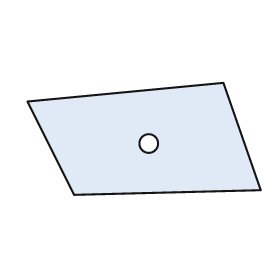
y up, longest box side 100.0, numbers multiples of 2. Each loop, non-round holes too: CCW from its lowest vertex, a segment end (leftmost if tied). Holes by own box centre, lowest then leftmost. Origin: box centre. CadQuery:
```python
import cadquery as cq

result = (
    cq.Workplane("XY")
    .moveTo(-30.0, -24.0)
    .lineTo(50.0, -22.0)
    .lineTo(34.0, 24.0)
    .lineTo(-50.0, 16.0)
    .close()
    .moveTo(2.0, -2.0)
    .circle(4.0)
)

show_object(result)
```